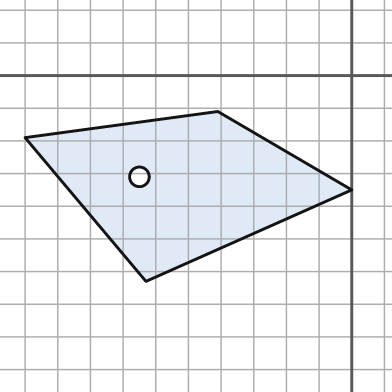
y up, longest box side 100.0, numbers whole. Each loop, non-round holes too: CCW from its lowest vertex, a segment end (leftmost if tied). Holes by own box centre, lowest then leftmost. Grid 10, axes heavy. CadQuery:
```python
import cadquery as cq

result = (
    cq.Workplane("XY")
    .moveTo(-63.0, -63.0)
    .lineTo(0.0, -35.0)
    .lineTo(-41.0, -11.0)
    .lineTo(-100.0, -19.0)
    .close()
    .moveTo(-65.0, -31.0)
    .circle(3.0)
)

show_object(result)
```